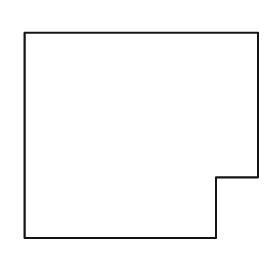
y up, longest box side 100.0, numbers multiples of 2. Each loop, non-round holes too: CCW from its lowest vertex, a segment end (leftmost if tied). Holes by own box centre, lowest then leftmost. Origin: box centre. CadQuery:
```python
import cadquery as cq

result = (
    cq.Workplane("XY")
    .moveTo(-50.0, -44.0)
    .lineTo(32.0, -44.0)
    .lineTo(32.0, -18.0)
    .lineTo(50.0, -18.0)
    .lineTo(50.0, 44.0)
    .lineTo(-50.0, 44.0)
    .close()
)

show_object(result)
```